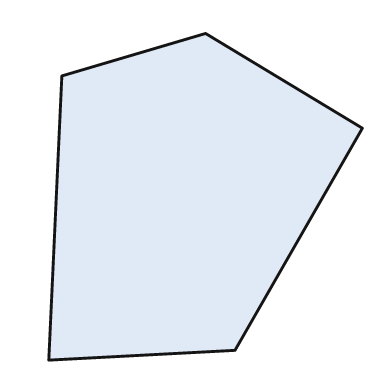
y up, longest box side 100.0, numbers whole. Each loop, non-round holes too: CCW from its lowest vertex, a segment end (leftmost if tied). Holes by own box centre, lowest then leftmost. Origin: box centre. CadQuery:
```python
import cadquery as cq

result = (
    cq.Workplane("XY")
    .moveTo(-48.0, -50.0)
    .lineTo(9.0, -47.0)
    .lineTo(48.0, 21.0)
    .lineTo(0.0, 50.0)
    .lineTo(-44.0, 37.0)
    .close()
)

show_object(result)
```